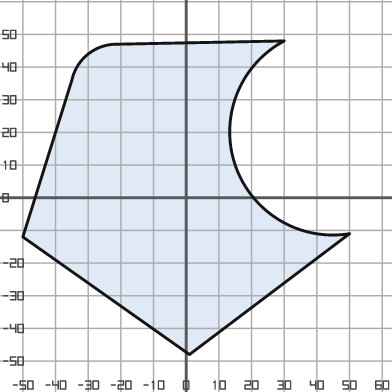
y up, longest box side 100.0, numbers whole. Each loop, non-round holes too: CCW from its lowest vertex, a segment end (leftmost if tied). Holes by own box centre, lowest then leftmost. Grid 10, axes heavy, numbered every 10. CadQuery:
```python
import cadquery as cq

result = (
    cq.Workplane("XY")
    .moveTo(1.0, -48.0)
    .lineTo(50.0, -11.0)
    .threePointArc((15.0, 10.0), (30.0, 48.0))
    .lineTo(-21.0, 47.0)
    .threePointArc((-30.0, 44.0), (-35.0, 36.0))
    .lineTo(-50.0, -12.0)
    .close()
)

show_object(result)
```